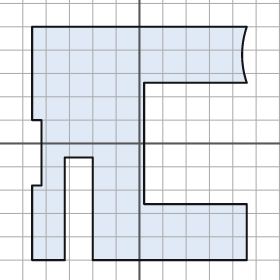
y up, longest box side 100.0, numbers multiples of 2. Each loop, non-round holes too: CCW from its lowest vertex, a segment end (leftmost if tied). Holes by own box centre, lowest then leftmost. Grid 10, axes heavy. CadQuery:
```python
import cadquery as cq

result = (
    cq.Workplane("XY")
    .moveTo(-46.0, -50.0)
    .lineTo(-32.0, -50.0)
    .lineTo(-32.0, -6.0)
    .lineTo(-20.0, -6.0)
    .lineTo(-20.0, -50.0)
    .lineTo(46.0, -50.0)
    .lineTo(46.0, -26.0)
    .lineTo(2.0, -26.0)
    .lineTo(2.0, 26.0)
    .lineTo(46.0, 26.0)
    .threePointArc((44.0, 38.0), (46.0, 50.0))
    .lineTo(-46.0, 50.0)
    .lineTo(-46.0, 10.0)
    .lineTo(-42.0, 10.0)
    .lineTo(-42.0, -18.0)
    .lineTo(-46.0, -18.0)
    .close()
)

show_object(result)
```